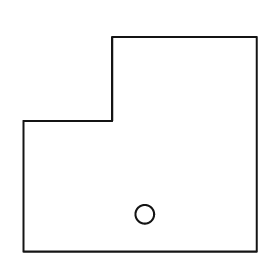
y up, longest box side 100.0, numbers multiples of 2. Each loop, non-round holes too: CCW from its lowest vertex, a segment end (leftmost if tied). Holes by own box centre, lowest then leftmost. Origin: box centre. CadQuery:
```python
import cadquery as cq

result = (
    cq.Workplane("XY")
    .moveTo(-50.0, -46.0)
    .lineTo(50.0, -46.0)
    .lineTo(50.0, 46.0)
    .lineTo(-12.0, 46.0)
    .lineTo(-12.0, 10.0)
    .lineTo(-50.0, 10.0)
    .close()
    .moveTo(2.0, -30.0)
    .circle(4.0)
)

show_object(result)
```